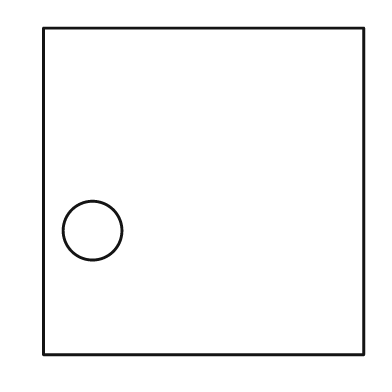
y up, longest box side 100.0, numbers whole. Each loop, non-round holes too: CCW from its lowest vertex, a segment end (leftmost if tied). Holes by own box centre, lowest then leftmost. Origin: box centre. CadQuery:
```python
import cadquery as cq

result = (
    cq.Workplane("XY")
    .moveTo(-49.0, -50.0)
    .lineTo(49.0, -50.0)
    .lineTo(49.0, 50.0)
    .lineTo(-49.0, 50.0)
    .close()
    .moveTo(-34.0, -12.0)
    .circle(9.0)
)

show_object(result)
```